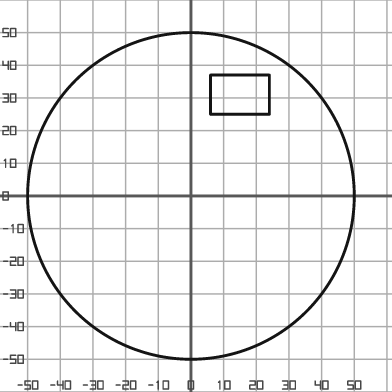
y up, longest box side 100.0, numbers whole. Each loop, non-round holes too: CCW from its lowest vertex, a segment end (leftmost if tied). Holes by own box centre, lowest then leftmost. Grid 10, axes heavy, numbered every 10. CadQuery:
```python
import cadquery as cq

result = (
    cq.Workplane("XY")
    .moveTo(0.0, 0.0)
    .circle(50.0)
    .moveTo(6.0, 25.0)
    .lineTo(24.0, 25.0)
    .lineTo(24.0, 37.0)
    .lineTo(6.0, 37.0)
    .close()
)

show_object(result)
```